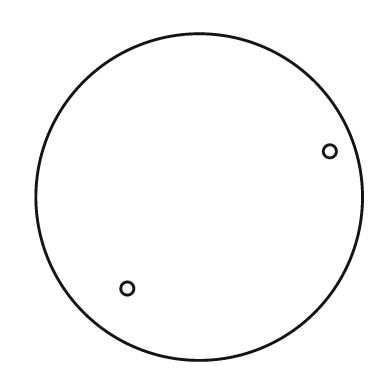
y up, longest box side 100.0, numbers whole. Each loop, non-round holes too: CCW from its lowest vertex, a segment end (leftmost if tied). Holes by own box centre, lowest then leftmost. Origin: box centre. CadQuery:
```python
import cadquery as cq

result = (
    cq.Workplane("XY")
    .moveTo(0.0, 0.0)
    .circle(50.0)
    .moveTo(-22.0, -28.0)
    .circle(2.0)
    .moveTo(40.0, 14.0)
    .circle(2.0)
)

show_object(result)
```